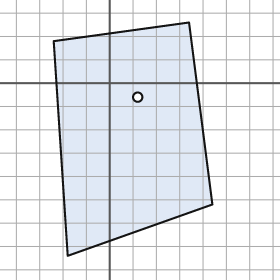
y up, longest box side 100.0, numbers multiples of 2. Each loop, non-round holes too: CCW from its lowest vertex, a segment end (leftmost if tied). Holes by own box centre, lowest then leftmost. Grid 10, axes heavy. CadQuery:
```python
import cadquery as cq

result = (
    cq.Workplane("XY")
    .moveTo(-18.0, -74.0)
    .lineTo(44.0, -52.0)
    .lineTo(34.0, 26.0)
    .lineTo(-24.0, 18.0)
    .close()
    .moveTo(12.0, -6.0)
    .circle(2.0)
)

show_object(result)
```